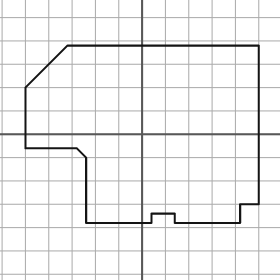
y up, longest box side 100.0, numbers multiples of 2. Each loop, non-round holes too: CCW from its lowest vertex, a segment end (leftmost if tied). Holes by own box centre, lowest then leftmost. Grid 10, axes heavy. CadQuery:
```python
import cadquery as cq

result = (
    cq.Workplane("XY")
    .moveTo(-24.0, -38.0)
    .lineTo(4.0, -38.0)
    .lineTo(4.0, -34.0)
    .lineTo(14.0, -34.0)
    .lineTo(14.0, -38.0)
    .lineTo(42.0, -38.0)
    .lineTo(42.0, -30.0)
    .lineTo(50.0, -30.0)
    .lineTo(50.0, 38.0)
    .lineTo(-32.0, 38.0)
    .lineTo(-50.0, 20.0)
    .lineTo(-50.0, -6.0)
    .lineTo(-28.0, -6.0)
    .lineTo(-24.0, -10.0)
    .close()
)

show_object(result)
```